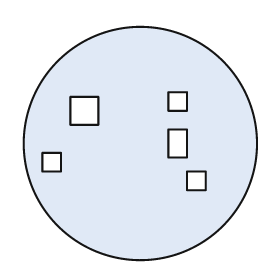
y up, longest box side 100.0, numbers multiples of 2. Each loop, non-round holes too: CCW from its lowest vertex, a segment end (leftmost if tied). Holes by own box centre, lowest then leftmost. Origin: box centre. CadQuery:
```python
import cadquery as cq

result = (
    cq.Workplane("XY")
    .moveTo(0.0, 0.0)
    .circle(50.0)
    .moveTo(20.0, -20.0)
    .lineTo(28.0, -20.0)
    .lineTo(28.0, -12.0)
    .lineTo(20.0, -12.0)
    .close()
    .moveTo(-42.0, -12.0)
    .lineTo(-34.0, -12.0)
    .lineTo(-34.0, -4.0)
    .lineTo(-42.0, -4.0)
    .close()
    .moveTo(12.0, -6.0)
    .lineTo(20.0, -6.0)
    .lineTo(20.0, 6.0)
    .lineTo(12.0, 6.0)
    .close()
    .moveTo(-30.0, 8.0)
    .lineTo(-18.0, 8.0)
    .lineTo(-18.0, 20.0)
    .lineTo(-30.0, 20.0)
    .close()
    .moveTo(12.0, 14.0)
    .lineTo(20.0, 14.0)
    .lineTo(20.0, 22.0)
    .lineTo(12.0, 22.0)
    .close()
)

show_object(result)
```